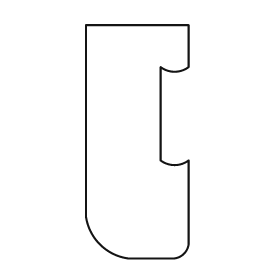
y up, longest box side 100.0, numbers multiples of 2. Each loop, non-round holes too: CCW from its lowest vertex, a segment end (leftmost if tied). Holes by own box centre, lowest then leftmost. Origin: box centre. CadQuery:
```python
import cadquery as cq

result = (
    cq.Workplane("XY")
    .moveTo(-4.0, -50.0)
    .lineTo(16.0, -50.0)
    .threePointArc((20.0, -48.0), (22.0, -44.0))
    .lineTo(22.0, -8.0)
    .threePointArc((16.0, -10.0), (10.0, -8.0))
    .lineTo(10.0, 32.0)
    .threePointArc((16.0, 30.0), (22.0, 32.0))
    .lineTo(22.0, 50.0)
    .lineTo(-22.0, 50.0)
    .lineTo(-22.0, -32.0)
    .threePointArc((-16.0, -44.0), (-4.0, -50.0))
    .close()
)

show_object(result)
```